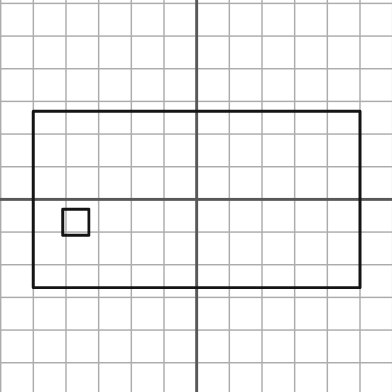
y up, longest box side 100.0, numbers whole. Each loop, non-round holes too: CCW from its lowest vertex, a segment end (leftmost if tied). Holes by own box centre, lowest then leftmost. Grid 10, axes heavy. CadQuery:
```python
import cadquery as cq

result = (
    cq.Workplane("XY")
    .moveTo(-50.0, -27.0)
    .lineTo(50.0, -27.0)
    .lineTo(50.0, 27.0)
    .lineTo(-50.0, 27.0)
    .close()
    .moveTo(-41.0, -11.0)
    .lineTo(-33.0, -11.0)
    .lineTo(-33.0, -3.0)
    .lineTo(-41.0, -3.0)
    .close()
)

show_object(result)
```